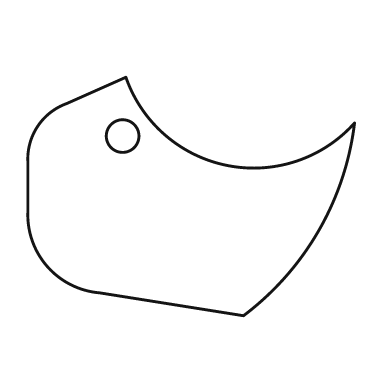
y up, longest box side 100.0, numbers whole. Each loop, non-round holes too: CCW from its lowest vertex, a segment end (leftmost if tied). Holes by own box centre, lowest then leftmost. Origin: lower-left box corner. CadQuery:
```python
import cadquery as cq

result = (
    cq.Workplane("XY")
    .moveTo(66.0, 0.0)
    .threePointArc((89.0, 26.0), (100.0, 59.0))
    .threePointArc((61.0, 46.0), (30.0, 73.0))
    .lineTo(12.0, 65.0)
    .threePointArc((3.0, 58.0), (0.0, 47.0))
    .lineTo(0.0, 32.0)
    .threePointArc((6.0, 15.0), (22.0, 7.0))
    .close()
    .moveTo(29.0, 55.0)
    .circle(5.0)
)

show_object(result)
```